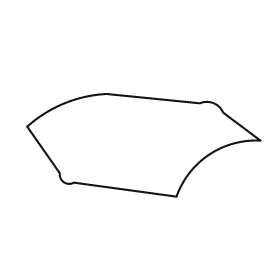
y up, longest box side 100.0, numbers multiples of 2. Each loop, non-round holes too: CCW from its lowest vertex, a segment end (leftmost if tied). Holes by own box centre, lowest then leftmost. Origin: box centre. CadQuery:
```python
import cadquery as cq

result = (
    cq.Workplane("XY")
    .moveTo(14.0, -22.0)
    .threePointArc((28.0, -4.0), (50.0, 2.0))
    .lineTo(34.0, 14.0)
    .threePointArc((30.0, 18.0), (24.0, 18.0))
    .lineTo(-16.0, 22.0)
    .threePointArc((-34.0, 18.0), (-50.0, 8.0))
    .lineTo(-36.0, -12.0)
    .threePointArc((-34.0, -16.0), (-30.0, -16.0))
    .close()
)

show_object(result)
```